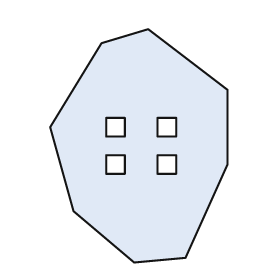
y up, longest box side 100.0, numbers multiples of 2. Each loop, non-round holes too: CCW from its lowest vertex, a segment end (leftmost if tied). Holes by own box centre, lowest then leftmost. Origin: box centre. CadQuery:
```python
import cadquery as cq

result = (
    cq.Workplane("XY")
    .moveTo(-2.0, -50.0)
    .lineTo(20.0, -48.0)
    .lineTo(38.0, -8.0)
    .lineTo(38.0, 24.0)
    .lineTo(4.0, 50.0)
    .lineTo(-16.0, 44.0)
    .lineTo(-38.0, 8.0)
    .lineTo(-28.0, -28.0)
    .close()
    .moveTo(-14.0, -12.0)
    .lineTo(-6.0, -12.0)
    .lineTo(-6.0, -4.0)
    .lineTo(-14.0, -4.0)
    .close()
    .moveTo(8.0, -12.0)
    .lineTo(16.0, -12.0)
    .lineTo(16.0, -4.0)
    .lineTo(8.0, -4.0)
    .close()
    .moveTo(-14.0, 4.0)
    .lineTo(-6.0, 4.0)
    .lineTo(-6.0, 12.0)
    .lineTo(-14.0, 12.0)
    .close()
    .moveTo(8.0, 4.0)
    .lineTo(16.0, 4.0)
    .lineTo(16.0, 12.0)
    .lineTo(8.0, 12.0)
    .close()
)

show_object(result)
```